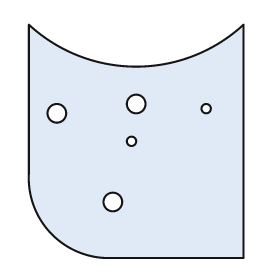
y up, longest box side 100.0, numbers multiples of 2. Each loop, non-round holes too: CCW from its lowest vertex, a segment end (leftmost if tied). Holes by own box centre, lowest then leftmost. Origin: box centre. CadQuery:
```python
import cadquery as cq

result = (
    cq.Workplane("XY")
    .moveTo(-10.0, -50.0)
    .lineTo(46.0, -50.0)
    .lineTo(46.0, 50.0)
    .threePointArc((0.0, 32.0), (-46.0, 50.0))
    .lineTo(-46.0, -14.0)
    .threePointArc((-36.0, -40.0), (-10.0, -50.0))
    .close()
    .moveTo(-10.0, -26.0)
    .circle(4.0)
    .moveTo(-2.0, 0.0)
    .circle(2.0)
    .moveTo(-34.0, 12.0)
    .circle(4.0)
    .moveTo(30.0, 14.0)
    .circle(2.0)
    .moveTo(0.0, 16.0)
    .circle(4.0)
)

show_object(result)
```